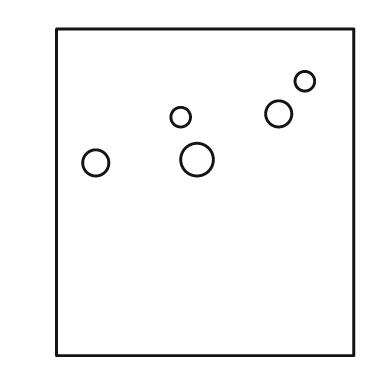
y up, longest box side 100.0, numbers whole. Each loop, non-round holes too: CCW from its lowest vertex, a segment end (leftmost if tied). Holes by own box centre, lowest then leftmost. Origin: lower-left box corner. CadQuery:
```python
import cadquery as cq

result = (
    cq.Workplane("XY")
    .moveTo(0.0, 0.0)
    .lineTo(91.0, 0.0)
    .lineTo(91.0, 100.0)
    .lineTo(0.0, 100.0)
    .close()
    .moveTo(12.0, 59.0)
    .circle(4.0)
    .moveTo(43.0, 60.0)
    .circle(5.0)
    .moveTo(38.0, 73.0)
    .circle(3.0)
    .moveTo(68.0, 74.0)
    .circle(4.0)
    .moveTo(76.0, 84.0)
    .circle(3.0)
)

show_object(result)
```